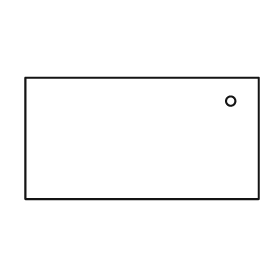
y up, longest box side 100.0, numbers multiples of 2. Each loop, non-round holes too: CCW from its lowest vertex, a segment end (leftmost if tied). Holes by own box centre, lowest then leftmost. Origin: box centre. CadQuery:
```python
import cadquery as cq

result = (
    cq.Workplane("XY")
    .moveTo(-50.0, -26.0)
    .lineTo(50.0, -26.0)
    .lineTo(50.0, 26.0)
    .lineTo(-50.0, 26.0)
    .close()
    .moveTo(38.0, 16.0)
    .circle(2.0)
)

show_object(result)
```